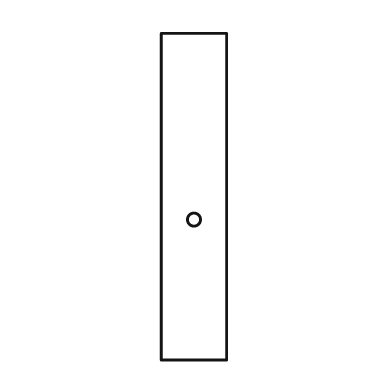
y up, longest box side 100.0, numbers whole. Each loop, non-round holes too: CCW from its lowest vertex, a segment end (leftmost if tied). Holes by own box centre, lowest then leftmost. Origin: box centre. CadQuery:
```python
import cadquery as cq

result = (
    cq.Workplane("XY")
    .moveTo(-10.0, -50.0)
    .lineTo(10.0, -50.0)
    .lineTo(10.0, 50.0)
    .lineTo(-10.0, 50.0)
    .close()
    .moveTo(0.0, -7.0)
    .circle(2.0)
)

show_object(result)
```